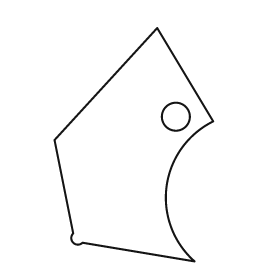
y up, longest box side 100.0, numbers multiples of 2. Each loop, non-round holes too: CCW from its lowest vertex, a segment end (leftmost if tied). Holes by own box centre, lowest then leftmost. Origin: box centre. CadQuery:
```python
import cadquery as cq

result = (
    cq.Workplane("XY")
    .moveTo(26.0, -50.0)
    .threePointArc((14.0, -18.0), (34.0, 10.0))
    .lineTo(10.0, 50.0)
    .lineTo(-34.0, 2.0)
    .lineTo(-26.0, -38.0)
    .threePointArc((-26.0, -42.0), (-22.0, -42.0))
    .close()
    .moveTo(18.0, 12.0)
    .circle(6.0)
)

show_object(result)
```